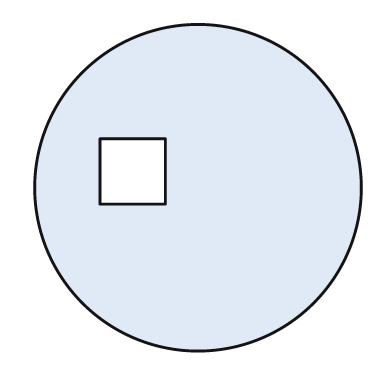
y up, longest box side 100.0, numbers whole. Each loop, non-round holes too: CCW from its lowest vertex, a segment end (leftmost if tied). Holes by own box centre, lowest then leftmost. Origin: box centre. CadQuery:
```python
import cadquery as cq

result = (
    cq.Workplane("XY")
    .moveTo(0.0, 0.0)
    .circle(50.0)
    .moveTo(-30.0, -5.0)
    .lineTo(-10.0, -5.0)
    .lineTo(-10.0, 15.0)
    .lineTo(-30.0, 15.0)
    .close()
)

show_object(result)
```